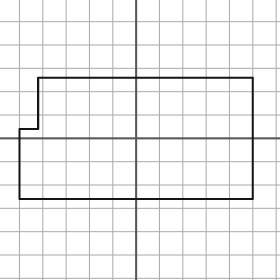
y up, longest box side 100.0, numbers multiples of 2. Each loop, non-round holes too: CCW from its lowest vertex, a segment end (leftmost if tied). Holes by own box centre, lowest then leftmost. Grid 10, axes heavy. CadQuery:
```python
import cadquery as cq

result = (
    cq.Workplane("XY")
    .moveTo(-50.0, -26.0)
    .lineTo(50.0, -26.0)
    .lineTo(50.0, 26.0)
    .lineTo(-42.0, 26.0)
    .lineTo(-42.0, 4.0)
    .lineTo(-50.0, 4.0)
    .close()
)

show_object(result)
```